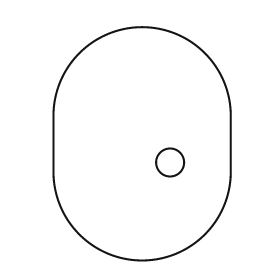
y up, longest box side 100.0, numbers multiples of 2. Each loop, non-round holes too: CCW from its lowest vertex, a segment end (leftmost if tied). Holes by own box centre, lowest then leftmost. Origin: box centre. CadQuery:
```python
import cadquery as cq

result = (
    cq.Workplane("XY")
    .moveTo(-38.0, -12.0)
    .threePointArc((0.0, -50.0), (38.0, -12.0))
    .lineTo(38.0, 12.0)
    .threePointArc((0.0, 50.0), (-38.0, 12.0))
    .close()
    .moveTo(12.0, -8.0)
    .circle(6.0)
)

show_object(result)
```